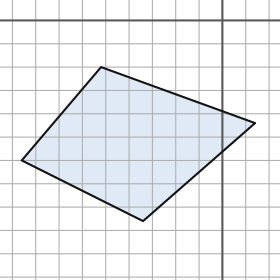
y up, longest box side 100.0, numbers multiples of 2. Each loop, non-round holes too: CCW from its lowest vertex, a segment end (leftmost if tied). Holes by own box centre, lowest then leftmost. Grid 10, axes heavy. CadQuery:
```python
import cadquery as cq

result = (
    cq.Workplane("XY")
    .moveTo(-34.0, -86.0)
    .lineTo(14.0, -44.0)
    .lineTo(-52.0, -20.0)
    .lineTo(-86.0, -60.0)
    .close()
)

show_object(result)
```